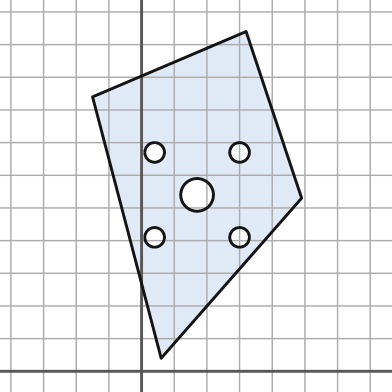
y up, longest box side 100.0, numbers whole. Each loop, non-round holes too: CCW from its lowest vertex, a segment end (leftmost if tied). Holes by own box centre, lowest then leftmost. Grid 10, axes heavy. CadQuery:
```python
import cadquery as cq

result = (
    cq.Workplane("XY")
    .moveTo(6.0, 4.0)
    .lineTo(49.0, 53.0)
    .lineTo(32.0, 104.0)
    .lineTo(-15.0, 84.0)
    .close()
    .moveTo(4.0, 41.0)
    .circle(3.0)
    .moveTo(30.0, 41.0)
    .circle(3.0)
    .moveTo(17.0, 54.0)
    .circle(5.0)
    .moveTo(4.0, 67.0)
    .circle(3.0)
    .moveTo(30.0, 67.0)
    .circle(3.0)
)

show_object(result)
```